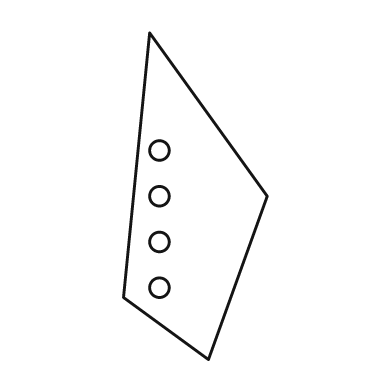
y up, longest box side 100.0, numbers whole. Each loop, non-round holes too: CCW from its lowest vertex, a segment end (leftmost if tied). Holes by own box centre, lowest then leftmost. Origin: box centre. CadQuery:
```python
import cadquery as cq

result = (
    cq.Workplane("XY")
    .moveTo(4.0, -50.0)
    .lineTo(22.0, 0.0)
    .lineTo(-14.0, 50.0)
    .lineTo(-22.0, -31.0)
    .close()
    .moveTo(-11.0, -28.0)
    .circle(3.0)
    .moveTo(-11.0, -14.0)
    .circle(3.0)
    .moveTo(-11.0, 0.0)
    .circle(3.0)
    .moveTo(-11.0, 14.0)
    .circle(3.0)
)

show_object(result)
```